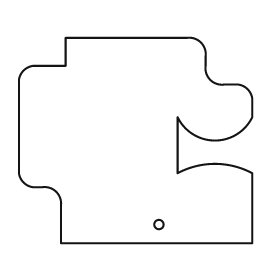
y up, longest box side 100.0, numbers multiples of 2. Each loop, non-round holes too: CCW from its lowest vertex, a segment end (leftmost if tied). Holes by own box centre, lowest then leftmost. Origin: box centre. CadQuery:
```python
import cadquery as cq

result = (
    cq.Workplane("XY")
    .moveTo(-32.0, -44.0)
    .lineTo(50.0, -44.0)
    .lineTo(50.0, -14.0)
    .threePointArc((34.0, -10.0), (18.0, -14.0))
    .lineTo(18.0, 10.0)
    .threePointArc((34.0, 0.0), (50.0, 10.0))
    .lineTo(50.0, 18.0)
    .threePointArc((48.0, 22.0), (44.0, 24.0))
    .lineTo(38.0, 24.0)
    .threePointArc((32.0, 26.0), (30.0, 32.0))
    .lineTo(30.0, 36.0)
    .threePointArc((28.0, 42.0), (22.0, 44.0))
    .lineTo(-30.0, 44.0)
    .lineTo(-30.0, 32.0)
    .lineTo(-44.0, 32.0)
    .threePointArc((-48.0, 30.0), (-50.0, 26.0))
    .lineTo(-50.0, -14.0)
    .threePointArc((-48.0, -18.0), (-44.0, -20.0))
    .lineTo(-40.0, -20.0)
    .threePointArc((-34.0, -22.0), (-32.0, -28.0))
    .close()
    .moveTo(10.0, -36.0)
    .circle(2.0)
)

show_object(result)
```